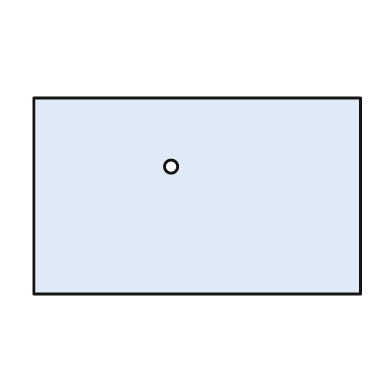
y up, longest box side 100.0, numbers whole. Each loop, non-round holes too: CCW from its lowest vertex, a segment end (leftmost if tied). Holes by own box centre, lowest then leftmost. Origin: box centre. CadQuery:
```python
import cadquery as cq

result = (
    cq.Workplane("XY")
    .moveTo(-50.0, -30.0)
    .lineTo(50.0, -30.0)
    .lineTo(50.0, 30.0)
    .lineTo(-50.0, 30.0)
    .close()
    .moveTo(-8.0, 9.0)
    .circle(2.0)
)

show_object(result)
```